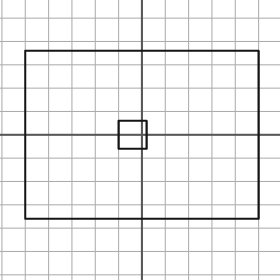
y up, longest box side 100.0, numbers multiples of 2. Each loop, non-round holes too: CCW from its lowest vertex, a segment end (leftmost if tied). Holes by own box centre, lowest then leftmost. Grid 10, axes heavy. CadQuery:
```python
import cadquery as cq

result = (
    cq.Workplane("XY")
    .moveTo(-50.0, -36.0)
    .lineTo(50.0, -36.0)
    .lineTo(50.0, 36.0)
    .lineTo(-50.0, 36.0)
    .close()
    .moveTo(-10.0, -6.0)
    .lineTo(2.0, -6.0)
    .lineTo(2.0, 6.0)
    .lineTo(-10.0, 6.0)
    .close()
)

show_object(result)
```